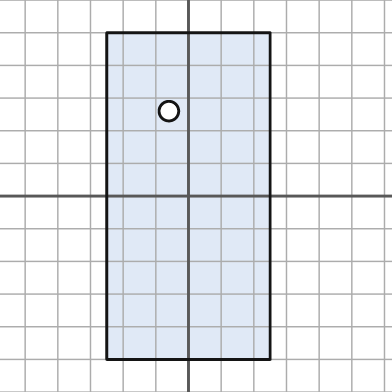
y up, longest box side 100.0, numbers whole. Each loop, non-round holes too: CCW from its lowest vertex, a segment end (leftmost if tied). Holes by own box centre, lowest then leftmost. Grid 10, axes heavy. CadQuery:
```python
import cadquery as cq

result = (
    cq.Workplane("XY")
    .moveTo(-25.0, -50.0)
    .lineTo(25.0, -50.0)
    .lineTo(25.0, 50.0)
    .lineTo(-25.0, 50.0)
    .close()
    .moveTo(-6.0, 26.0)
    .circle(3.0)
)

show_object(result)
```